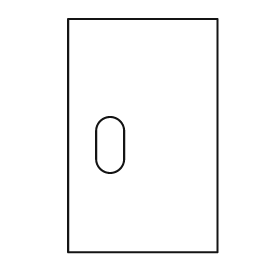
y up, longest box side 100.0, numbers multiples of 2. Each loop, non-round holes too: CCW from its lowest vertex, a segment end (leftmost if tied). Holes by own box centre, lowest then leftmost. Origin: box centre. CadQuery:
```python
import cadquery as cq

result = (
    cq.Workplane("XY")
    .moveTo(-32.0, -50.0)
    .lineTo(32.0, -50.0)
    .lineTo(32.0, 50.0)
    .lineTo(-32.0, 50.0)
    .close()
    .moveTo(-20.0, -10.0)
    .threePointArc((-14.0, -16.0), (-8.0, -10.0))
    .lineTo(-8.0, 2.0)
    .threePointArc((-14.0, 8.0), (-20.0, 2.0))
    .close()
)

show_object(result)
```